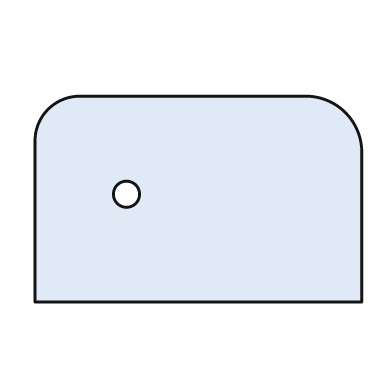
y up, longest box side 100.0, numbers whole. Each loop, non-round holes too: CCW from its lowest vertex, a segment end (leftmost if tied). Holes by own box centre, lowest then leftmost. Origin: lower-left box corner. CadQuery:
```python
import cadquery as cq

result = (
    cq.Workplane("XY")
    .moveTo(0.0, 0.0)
    .lineTo(100.0, 0.0)
    .lineTo(100.0, 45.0)
    .threePointArc((95.0, 58.0), (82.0, 63.0))
    .lineTo(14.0, 63.0)
    .threePointArc((4.0, 59.0), (0.0, 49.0))
    .close()
    .moveTo(28.0, 33.0)
    .circle(4.0)
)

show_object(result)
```